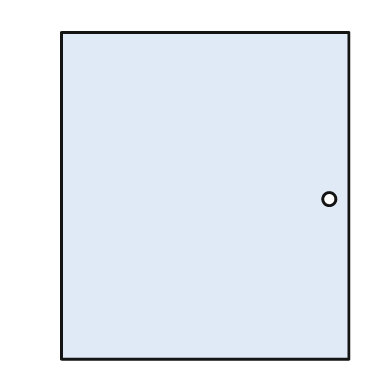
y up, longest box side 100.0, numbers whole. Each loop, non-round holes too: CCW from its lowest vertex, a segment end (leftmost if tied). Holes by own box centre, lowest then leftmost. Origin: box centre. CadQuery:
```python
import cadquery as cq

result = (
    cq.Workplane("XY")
    .moveTo(-44.0, -50.0)
    .lineTo(44.0, -50.0)
    .lineTo(44.0, 50.0)
    .lineTo(-44.0, 50.0)
    .close()
    .moveTo(38.0, -1.0)
    .circle(2.0)
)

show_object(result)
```